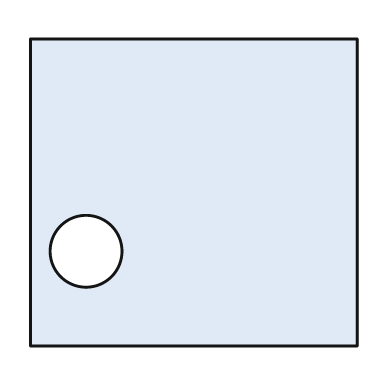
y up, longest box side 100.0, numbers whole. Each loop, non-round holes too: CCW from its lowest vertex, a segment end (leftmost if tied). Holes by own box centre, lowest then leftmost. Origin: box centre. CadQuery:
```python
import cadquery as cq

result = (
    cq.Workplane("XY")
    .moveTo(-50.0, -47.0)
    .lineTo(50.0, -47.0)
    .lineTo(50.0, 47.0)
    .lineTo(-50.0, 47.0)
    .close()
    .moveTo(-33.0, -18.0)
    .circle(11.0)
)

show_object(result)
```